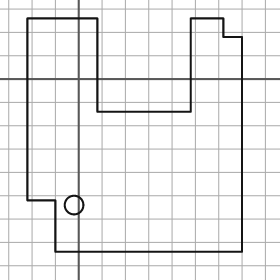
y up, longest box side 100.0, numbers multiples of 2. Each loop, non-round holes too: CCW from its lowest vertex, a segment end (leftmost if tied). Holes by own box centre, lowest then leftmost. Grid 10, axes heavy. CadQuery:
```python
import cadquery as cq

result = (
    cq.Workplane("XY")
    .moveTo(-10.0, -74.0)
    .lineTo(70.0, -74.0)
    .lineTo(70.0, 18.0)
    .lineTo(62.0, 18.0)
    .lineTo(62.0, 26.0)
    .lineTo(48.0, 26.0)
    .lineTo(48.0, -14.0)
    .lineTo(8.0, -14.0)
    .lineTo(8.0, 26.0)
    .lineTo(-22.0, 26.0)
    .lineTo(-22.0, -52.0)
    .lineTo(-10.0, -52.0)
    .close()
    .moveTo(-2.0, -54.0)
    .circle(4.0)
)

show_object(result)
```